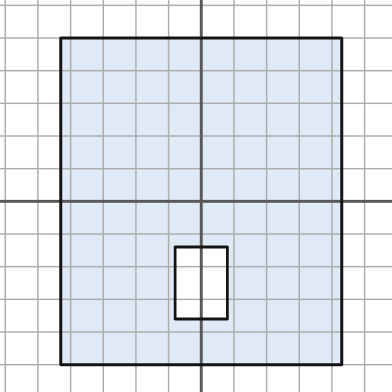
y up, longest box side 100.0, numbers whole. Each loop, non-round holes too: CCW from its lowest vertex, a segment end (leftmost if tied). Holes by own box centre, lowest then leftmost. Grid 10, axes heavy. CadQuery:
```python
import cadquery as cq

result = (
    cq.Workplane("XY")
    .moveTo(-43.0, -50.0)
    .lineTo(43.0, -50.0)
    .lineTo(43.0, 50.0)
    .lineTo(-43.0, 50.0)
    .close()
    .moveTo(-8.0, -36.0)
    .lineTo(8.0, -36.0)
    .lineTo(8.0, -14.0)
    .lineTo(-8.0, -14.0)
    .close()
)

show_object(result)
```